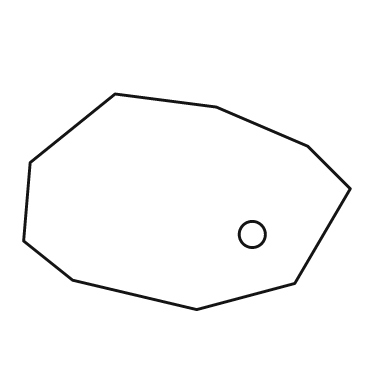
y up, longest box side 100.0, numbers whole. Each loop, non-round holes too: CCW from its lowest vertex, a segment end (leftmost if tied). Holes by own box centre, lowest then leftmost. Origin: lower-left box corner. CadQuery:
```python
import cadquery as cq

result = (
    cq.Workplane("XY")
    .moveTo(53.0, 0.0)
    .lineTo(83.0, 8.0)
    .lineTo(100.0, 37.0)
    .lineTo(87.0, 50.0)
    .lineTo(59.0, 62.0)
    .lineTo(28.0, 66.0)
    .lineTo(2.0, 45.0)
    .lineTo(0.0, 21.0)
    .lineTo(15.0, 9.0)
    .close()
    .moveTo(70.0, 23.0)
    .circle(4.0)
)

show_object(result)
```